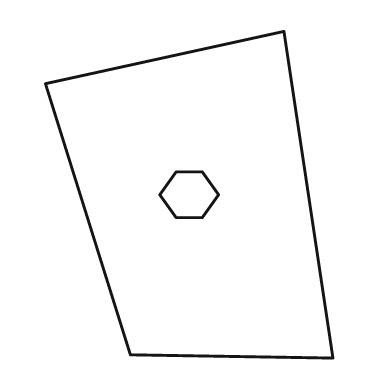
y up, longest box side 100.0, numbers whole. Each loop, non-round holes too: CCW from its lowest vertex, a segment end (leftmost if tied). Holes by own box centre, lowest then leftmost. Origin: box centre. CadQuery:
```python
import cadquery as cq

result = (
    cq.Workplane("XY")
    .moveTo(44.0, -50.0)
    .lineTo(29.0, 50.0)
    .lineTo(-44.0, 34.0)
    .lineTo(-18.0, -49.0)
    .close()
    .moveTo(-4.0, -7.0)
    .lineTo(4.0, -7.0)
    .lineTo(9.0, 0.0)
    .lineTo(4.0, 7.0)
    .lineTo(-4.0, 7.0)
    .lineTo(-9.0, 0.0)
    .close()
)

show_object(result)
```